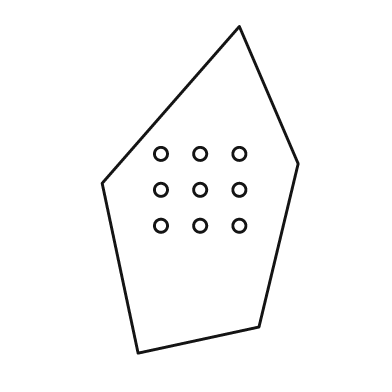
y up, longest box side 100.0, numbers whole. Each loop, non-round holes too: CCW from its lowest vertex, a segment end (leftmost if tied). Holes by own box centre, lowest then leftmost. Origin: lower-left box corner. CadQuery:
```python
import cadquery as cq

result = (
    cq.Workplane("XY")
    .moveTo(11.0, 0.0)
    .lineTo(48.0, 8.0)
    .lineTo(60.0, 58.0)
    .lineTo(42.0, 100.0)
    .lineTo(0.0, 52.0)
    .close()
    .moveTo(18.0, 39.0)
    .circle(2.0)
    .moveTo(30.0, 39.0)
    .circle(2.0)
    .moveTo(42.0, 39.0)
    .circle(2.0)
    .moveTo(18.0, 50.0)
    .circle(2.0)
    .moveTo(30.0, 50.0)
    .circle(2.0)
    .moveTo(42.0, 50.0)
    .circle(2.0)
    .moveTo(18.0, 61.0)
    .circle(2.0)
    .moveTo(30.0, 61.0)
    .circle(2.0)
    .moveTo(42.0, 61.0)
    .circle(2.0)
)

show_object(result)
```